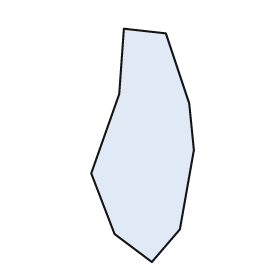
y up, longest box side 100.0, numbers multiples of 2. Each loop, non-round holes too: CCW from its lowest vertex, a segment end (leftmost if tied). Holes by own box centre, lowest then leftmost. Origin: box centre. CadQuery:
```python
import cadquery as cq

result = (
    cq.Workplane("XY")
    .moveTo(4.0, -50.0)
    .lineTo(16.0, -36.0)
    .lineTo(22.0, -2.0)
    .lineTo(20.0, 18.0)
    .lineTo(10.0, 48.0)
    .lineTo(-8.0, 50.0)
    .lineTo(-10.0, 22.0)
    .lineTo(-22.0, -12.0)
    .lineTo(-12.0, -38.0)
    .close()
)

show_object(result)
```